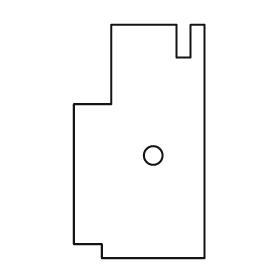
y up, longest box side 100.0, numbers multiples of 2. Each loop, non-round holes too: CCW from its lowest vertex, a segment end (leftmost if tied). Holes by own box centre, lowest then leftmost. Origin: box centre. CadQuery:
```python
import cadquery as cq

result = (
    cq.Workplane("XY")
    .moveTo(-16.0, -50.0)
    .lineTo(28.0, -50.0)
    .lineTo(28.0, 50.0)
    .lineTo(22.0, 50.0)
    .lineTo(22.0, 36.0)
    .lineTo(16.0, 36.0)
    .lineTo(16.0, 50.0)
    .lineTo(-12.0, 50.0)
    .lineTo(-12.0, 16.0)
    .lineTo(-28.0, 16.0)
    .lineTo(-28.0, -44.0)
    .lineTo(-16.0, -44.0)
    .close()
    .moveTo(6.0, -6.0)
    .circle(4.0)
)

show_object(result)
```